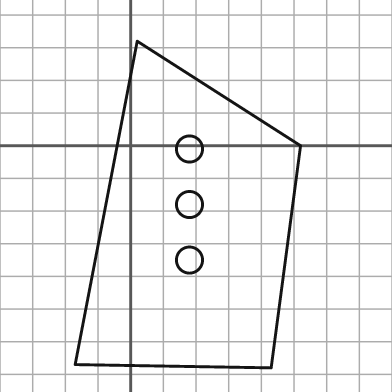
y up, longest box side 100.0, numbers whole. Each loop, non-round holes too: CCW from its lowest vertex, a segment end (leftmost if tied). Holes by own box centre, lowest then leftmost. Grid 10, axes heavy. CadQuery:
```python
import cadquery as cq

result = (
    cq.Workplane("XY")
    .moveTo(43.0, -68.0)
    .lineTo(52.0, 0.0)
    .lineTo(2.0, 32.0)
    .lineTo(-17.0, -67.0)
    .close()
    .moveTo(18.0, -35.0)
    .circle(4.0)
    .moveTo(18.0, -18.0)
    .circle(4.0)
    .moveTo(18.0, -1.0)
    .circle(4.0)
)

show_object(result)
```